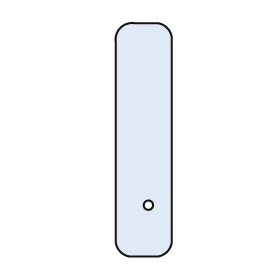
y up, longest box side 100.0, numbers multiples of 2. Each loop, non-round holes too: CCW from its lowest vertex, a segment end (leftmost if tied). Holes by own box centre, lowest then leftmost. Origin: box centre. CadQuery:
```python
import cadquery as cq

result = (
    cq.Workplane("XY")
    .moveTo(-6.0, -50.0)
    .lineTo(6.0, -50.0)
    .threePointArc((10.0, -48.0), (12.0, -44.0))
    .lineTo(12.0, 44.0)
    .threePointArc((10.0, 48.0), (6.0, 50.0))
    .lineTo(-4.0, 50.0)
    .threePointArc((-10.0, 48.0), (-12.0, 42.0))
    .lineTo(-12.0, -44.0)
    .threePointArc((-10.0, -48.0), (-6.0, -50.0))
    .close()
    .moveTo(2.0, -28.0)
    .circle(2.0)
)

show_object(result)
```